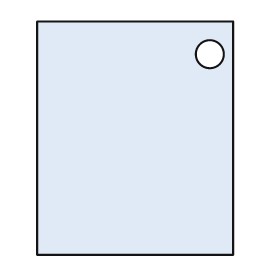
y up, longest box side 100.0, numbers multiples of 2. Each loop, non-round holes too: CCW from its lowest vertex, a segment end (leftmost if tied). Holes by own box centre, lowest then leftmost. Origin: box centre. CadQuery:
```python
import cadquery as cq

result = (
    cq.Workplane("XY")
    .moveTo(-42.0, -50.0)
    .lineTo(42.0, -50.0)
    .lineTo(42.0, 50.0)
    .lineTo(-42.0, 50.0)
    .close()
    .moveTo(32.0, 36.0)
    .circle(6.0)
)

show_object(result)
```